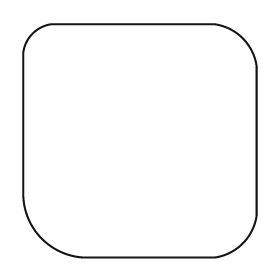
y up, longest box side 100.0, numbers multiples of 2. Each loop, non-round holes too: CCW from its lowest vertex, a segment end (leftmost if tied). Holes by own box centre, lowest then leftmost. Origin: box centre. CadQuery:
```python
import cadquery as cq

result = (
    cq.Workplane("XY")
    .moveTo(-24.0, -50.0)
    .lineTo(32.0, -50.0)
    .threePointArc((44.0, -44.0), (50.0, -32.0))
    .lineTo(50.0, 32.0)
    .threePointArc((44.0, 44.0), (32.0, 50.0))
    .lineTo(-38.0, 50.0)
    .threePointArc((-46.0, 46.0), (-50.0, 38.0))
    .lineTo(-50.0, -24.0)
    .threePointArc((-42.0, -42.0), (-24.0, -50.0))
    .close()
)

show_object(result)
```